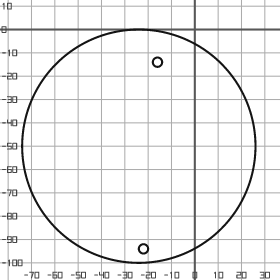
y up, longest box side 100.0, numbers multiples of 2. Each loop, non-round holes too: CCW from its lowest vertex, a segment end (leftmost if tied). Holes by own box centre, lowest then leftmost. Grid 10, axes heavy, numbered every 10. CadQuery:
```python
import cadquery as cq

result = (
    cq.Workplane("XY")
    .moveTo(-24.0, -50.0)
    .circle(50.0)
    .moveTo(-22.0, -94.0)
    .circle(2.0)
    .moveTo(-16.0, -14.0)
    .circle(2.0)
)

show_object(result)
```